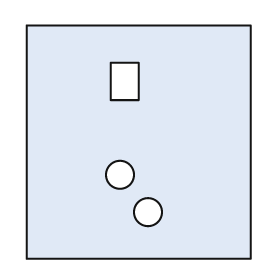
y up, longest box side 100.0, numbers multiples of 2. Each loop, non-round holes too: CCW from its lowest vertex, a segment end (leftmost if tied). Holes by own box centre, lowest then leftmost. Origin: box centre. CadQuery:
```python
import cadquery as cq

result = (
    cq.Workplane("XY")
    .moveTo(-48.0, -50.0)
    .lineTo(48.0, -50.0)
    .lineTo(48.0, 50.0)
    .lineTo(-48.0, 50.0)
    .close()
    .moveTo(4.0, -30.0)
    .circle(6.0)
    .moveTo(-8.0, -14.0)
    .circle(6.0)
    .moveTo(-12.0, 18.0)
    .lineTo(0.0, 18.0)
    .lineTo(0.0, 34.0)
    .lineTo(-12.0, 34.0)
    .close()
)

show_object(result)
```